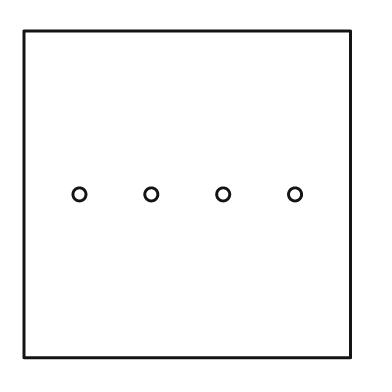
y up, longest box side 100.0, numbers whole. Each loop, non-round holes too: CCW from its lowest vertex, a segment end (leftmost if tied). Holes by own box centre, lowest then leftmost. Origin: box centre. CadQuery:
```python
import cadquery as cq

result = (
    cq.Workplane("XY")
    .moveTo(-50.0, -50.0)
    .lineTo(50.0, -50.0)
    .lineTo(50.0, 50.0)
    .lineTo(-50.0, 50.0)
    .close()
    .moveTo(-33.0, 0.0)
    .circle(2.0)
    .moveTo(-11.0, 0.0)
    .circle(2.0)
    .moveTo(11.0, 0.0)
    .circle(2.0)
    .moveTo(33.0, 0.0)
    .circle(2.0)
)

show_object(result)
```